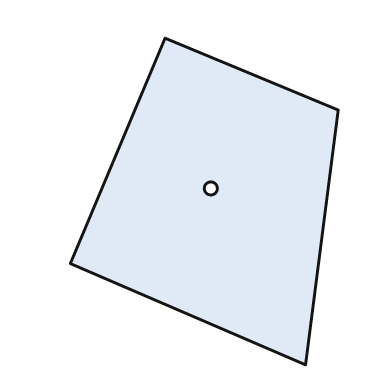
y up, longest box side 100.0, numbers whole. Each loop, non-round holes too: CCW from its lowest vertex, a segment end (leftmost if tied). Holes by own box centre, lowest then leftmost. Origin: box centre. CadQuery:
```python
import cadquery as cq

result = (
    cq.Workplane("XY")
    .moveTo(31.0, -50.0)
    .lineTo(41.0, 28.0)
    .lineTo(-12.0, 50.0)
    .lineTo(-41.0, -19.0)
    .close()
    .moveTo(2.0, 4.0)
    .circle(2.0)
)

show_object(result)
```